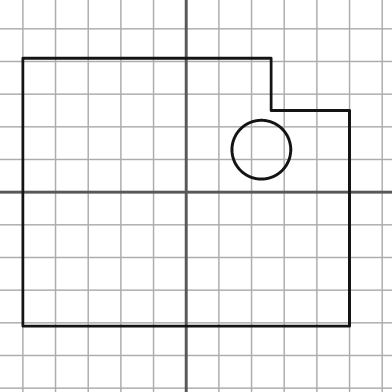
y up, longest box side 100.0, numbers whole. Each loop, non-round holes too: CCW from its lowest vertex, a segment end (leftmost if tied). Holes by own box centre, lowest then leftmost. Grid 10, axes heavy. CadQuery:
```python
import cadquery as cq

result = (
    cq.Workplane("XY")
    .moveTo(-50.0, -41.0)
    .lineTo(50.0, -41.0)
    .lineTo(50.0, 25.0)
    .lineTo(26.0, 25.0)
    .lineTo(26.0, 41.0)
    .lineTo(-50.0, 41.0)
    .close()
    .moveTo(23.0, 13.0)
    .circle(9.0)
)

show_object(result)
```